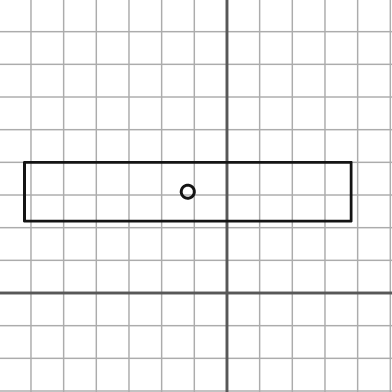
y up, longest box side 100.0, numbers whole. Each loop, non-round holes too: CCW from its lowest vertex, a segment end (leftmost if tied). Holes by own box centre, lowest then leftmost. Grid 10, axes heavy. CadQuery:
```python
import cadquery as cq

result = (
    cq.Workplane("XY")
    .moveTo(-62.0, 22.0)
    .lineTo(38.0, 22.0)
    .lineTo(38.0, 40.0)
    .lineTo(-62.0, 40.0)
    .close()
    .moveTo(-12.0, 31.0)
    .circle(2.0)
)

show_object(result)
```